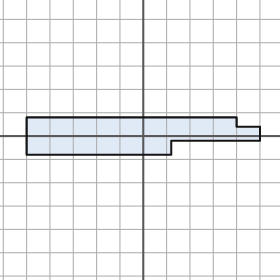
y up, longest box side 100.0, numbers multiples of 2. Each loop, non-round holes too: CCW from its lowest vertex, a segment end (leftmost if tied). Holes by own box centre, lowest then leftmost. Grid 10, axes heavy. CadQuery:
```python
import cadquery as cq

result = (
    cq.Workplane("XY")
    .moveTo(-50.0, -8.0)
    .lineTo(12.0, -8.0)
    .lineTo(12.0, -2.0)
    .lineTo(50.0, -2.0)
    .lineTo(50.0, 4.0)
    .lineTo(40.0, 4.0)
    .lineTo(40.0, 8.0)
    .lineTo(-50.0, 8.0)
    .close()
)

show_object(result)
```